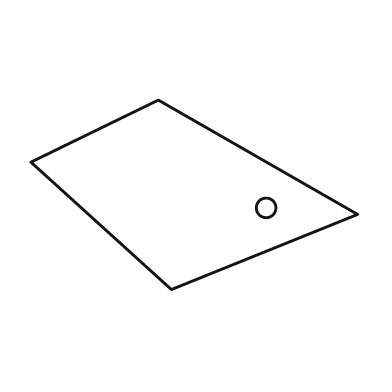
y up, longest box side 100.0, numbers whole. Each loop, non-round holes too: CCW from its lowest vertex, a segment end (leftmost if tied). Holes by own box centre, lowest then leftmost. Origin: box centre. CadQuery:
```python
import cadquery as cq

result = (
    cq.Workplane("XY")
    .moveTo(-7.0, -29.0)
    .lineTo(50.0, -6.0)
    .lineTo(-11.0, 29.0)
    .lineTo(-50.0, 10.0)
    .close()
    .moveTo(22.0, -4.0)
    .circle(3.0)
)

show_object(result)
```